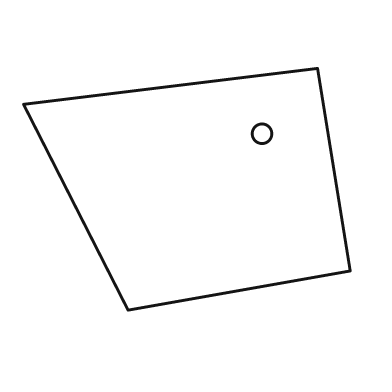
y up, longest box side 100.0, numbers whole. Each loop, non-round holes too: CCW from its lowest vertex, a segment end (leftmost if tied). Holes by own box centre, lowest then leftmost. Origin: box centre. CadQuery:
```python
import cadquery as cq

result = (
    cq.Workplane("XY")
    .moveTo(-18.0, -37.0)
    .lineTo(50.0, -25.0)
    .lineTo(40.0, 37.0)
    .lineTo(-50.0, 26.0)
    .close()
    .moveTo(23.0, 17.0)
    .circle(3.0)
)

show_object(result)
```